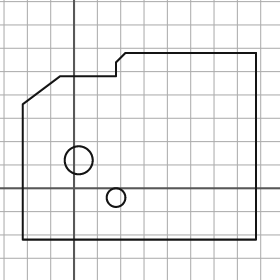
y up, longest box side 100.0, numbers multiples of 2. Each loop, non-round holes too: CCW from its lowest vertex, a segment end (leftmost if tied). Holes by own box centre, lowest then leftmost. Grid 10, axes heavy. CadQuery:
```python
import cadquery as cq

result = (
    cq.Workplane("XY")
    .moveTo(-22.0, -22.0)
    .lineTo(78.0, -22.0)
    .lineTo(78.0, 58.0)
    .lineTo(22.0, 58.0)
    .lineTo(18.0, 54.0)
    .lineTo(18.0, 48.0)
    .lineTo(-6.0, 48.0)
    .lineTo(-22.0, 36.0)
    .close()
    .moveTo(18.0, -4.0)
    .circle(4.0)
    .moveTo(2.0, 12.0)
    .circle(6.0)
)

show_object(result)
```